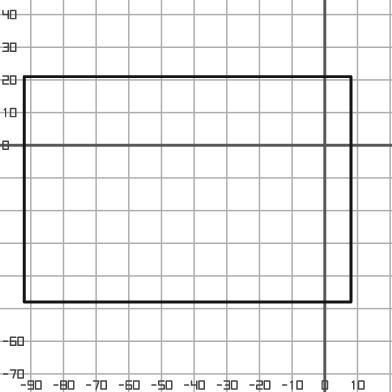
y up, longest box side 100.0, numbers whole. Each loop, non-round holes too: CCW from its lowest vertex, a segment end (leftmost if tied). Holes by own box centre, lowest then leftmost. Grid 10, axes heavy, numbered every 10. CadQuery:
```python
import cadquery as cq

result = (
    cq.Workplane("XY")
    .moveTo(-92.0, -48.0)
    .lineTo(8.0, -48.0)
    .lineTo(8.0, 21.0)
    .lineTo(-92.0, 21.0)
    .close()
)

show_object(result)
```